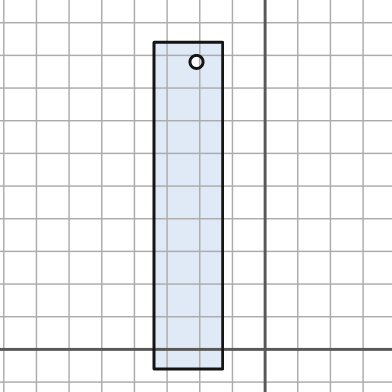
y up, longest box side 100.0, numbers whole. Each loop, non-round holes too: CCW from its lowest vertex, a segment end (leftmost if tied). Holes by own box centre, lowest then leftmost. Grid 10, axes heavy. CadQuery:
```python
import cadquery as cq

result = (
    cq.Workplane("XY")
    .moveTo(-34.0, -6.0)
    .lineTo(-13.0, -6.0)
    .lineTo(-13.0, 94.0)
    .lineTo(-34.0, 94.0)
    .close()
    .moveTo(-21.0, 88.0)
    .circle(2.0)
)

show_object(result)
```